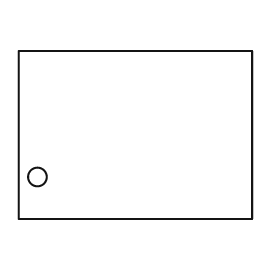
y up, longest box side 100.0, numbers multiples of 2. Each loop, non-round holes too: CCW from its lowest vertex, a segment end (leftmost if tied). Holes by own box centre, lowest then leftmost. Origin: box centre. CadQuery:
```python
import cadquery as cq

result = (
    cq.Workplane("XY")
    .moveTo(-50.0, -36.0)
    .lineTo(50.0, -36.0)
    .lineTo(50.0, 36.0)
    .lineTo(-50.0, 36.0)
    .close()
    .moveTo(-42.0, -18.0)
    .circle(4.0)
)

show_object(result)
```